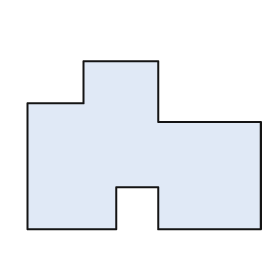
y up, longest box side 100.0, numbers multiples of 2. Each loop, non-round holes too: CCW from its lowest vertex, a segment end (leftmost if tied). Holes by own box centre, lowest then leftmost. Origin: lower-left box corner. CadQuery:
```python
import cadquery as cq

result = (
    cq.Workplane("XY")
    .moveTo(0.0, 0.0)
    .lineTo(38.0, 0.0)
    .lineTo(38.0, 18.0)
    .lineTo(56.0, 18.0)
    .lineTo(56.0, 0.0)
    .lineTo(100.0, 0.0)
    .lineTo(100.0, 46.0)
    .lineTo(56.0, 46.0)
    .lineTo(56.0, 72.0)
    .lineTo(24.0, 72.0)
    .lineTo(24.0, 54.0)
    .lineTo(0.0, 54.0)
    .close()
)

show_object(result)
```